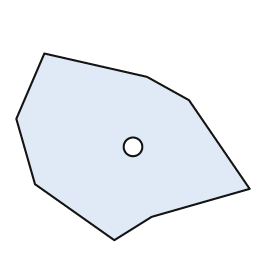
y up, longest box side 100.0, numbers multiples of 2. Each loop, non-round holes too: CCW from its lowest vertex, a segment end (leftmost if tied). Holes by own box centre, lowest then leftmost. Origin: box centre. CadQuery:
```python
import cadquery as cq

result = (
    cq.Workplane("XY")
    .moveTo(-8.0, -40.0)
    .lineTo(8.0, -30.0)
    .lineTo(50.0, -18.0)
    .lineTo(24.0, 20.0)
    .lineTo(6.0, 30.0)
    .lineTo(-38.0, 40.0)
    .lineTo(-50.0, 12.0)
    .lineTo(-42.0, -16.0)
    .close()
    .moveTo(0.0, 0.0)
    .circle(4.0)
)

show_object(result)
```